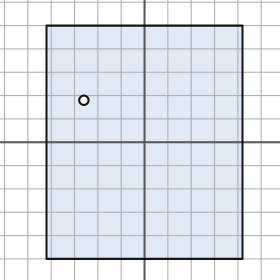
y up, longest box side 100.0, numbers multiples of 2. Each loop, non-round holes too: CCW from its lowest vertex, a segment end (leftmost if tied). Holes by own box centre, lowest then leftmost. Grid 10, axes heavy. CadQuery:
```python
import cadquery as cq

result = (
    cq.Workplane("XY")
    .moveTo(-42.0, -50.0)
    .lineTo(42.0, -50.0)
    .lineTo(42.0, 50.0)
    .lineTo(-42.0, 50.0)
    .close()
    .moveTo(-26.0, 18.0)
    .circle(2.0)
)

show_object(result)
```